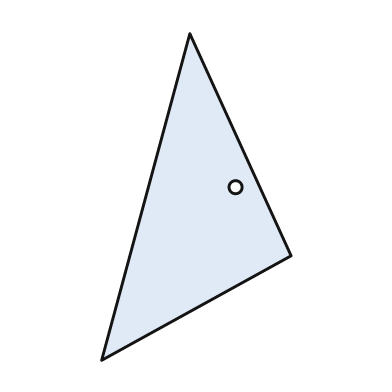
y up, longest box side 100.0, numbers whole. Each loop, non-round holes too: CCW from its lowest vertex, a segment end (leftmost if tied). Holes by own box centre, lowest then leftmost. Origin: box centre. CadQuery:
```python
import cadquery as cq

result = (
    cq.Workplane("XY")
    .moveTo(-29.0, -50.0)
    .lineTo(29.0, -18.0)
    .lineTo(-2.0, 50.0)
    .close()
    .moveTo(12.0, 3.0)
    .circle(2.0)
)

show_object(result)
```